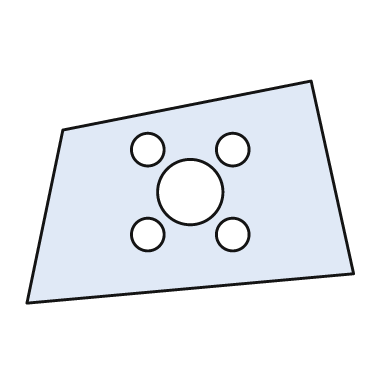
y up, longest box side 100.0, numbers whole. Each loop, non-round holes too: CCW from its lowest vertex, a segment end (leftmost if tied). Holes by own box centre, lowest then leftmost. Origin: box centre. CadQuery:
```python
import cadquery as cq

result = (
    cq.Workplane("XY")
    .moveTo(-50.0, -34.0)
    .lineTo(50.0, -25.0)
    .lineTo(37.0, 34.0)
    .lineTo(-39.0, 19.0)
    .close()
    .moveTo(-13.0, -13.0)
    .circle(5.0)
    .moveTo(13.0, -13.0)
    .circle(5.0)
    .moveTo(0.0, 0.0)
    .circle(10.0)
    .moveTo(-13.0, 13.0)
    .circle(5.0)
    .moveTo(13.0, 13.0)
    .circle(5.0)
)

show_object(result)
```